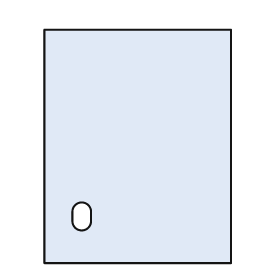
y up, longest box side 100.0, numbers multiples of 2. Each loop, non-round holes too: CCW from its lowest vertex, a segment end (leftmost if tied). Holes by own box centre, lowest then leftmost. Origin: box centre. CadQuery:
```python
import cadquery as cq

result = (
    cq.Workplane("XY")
    .moveTo(-40.0, -50.0)
    .lineTo(40.0, -50.0)
    .lineTo(40.0, 50.0)
    .lineTo(-40.0, 50.0)
    .close()
    .moveTo(-28.0, -32.0)
    .threePointArc((-24.0, -36.0), (-20.0, -32.0))
    .lineTo(-20.0, -28.0)
    .threePointArc((-24.0, -24.0), (-28.0, -28.0))
    .close()
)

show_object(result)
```